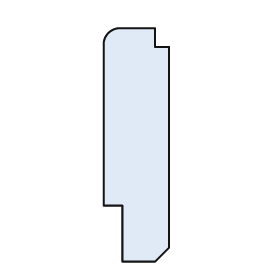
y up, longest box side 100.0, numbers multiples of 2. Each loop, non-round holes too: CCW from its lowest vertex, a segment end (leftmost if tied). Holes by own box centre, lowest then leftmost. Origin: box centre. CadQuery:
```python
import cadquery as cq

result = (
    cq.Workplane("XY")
    .moveTo(-6.0, -50.0)
    .lineTo(8.0, -50.0)
    .lineTo(14.0, -44.0)
    .lineTo(14.0, 42.0)
    .lineTo(8.0, 42.0)
    .lineTo(8.0, 50.0)
    .lineTo(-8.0, 50.0)
    .threePointArc((-12.0, 48.0), (-14.0, 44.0))
    .lineTo(-14.0, -26.0)
    .lineTo(-6.0, -26.0)
    .close()
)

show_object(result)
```